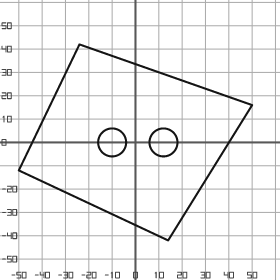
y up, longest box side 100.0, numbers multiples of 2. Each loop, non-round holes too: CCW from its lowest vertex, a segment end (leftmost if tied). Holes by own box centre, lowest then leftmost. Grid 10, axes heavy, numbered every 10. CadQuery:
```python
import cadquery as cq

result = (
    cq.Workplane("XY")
    .moveTo(14.0, -42.0)
    .lineTo(50.0, 16.0)
    .lineTo(-24.0, 42.0)
    .lineTo(-50.0, -12.0)
    .close()
    .moveTo(-10.0, 0.0)
    .circle(6.0)
    .moveTo(12.0, 0.0)
    .circle(6.0)
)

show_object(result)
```